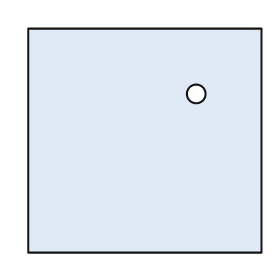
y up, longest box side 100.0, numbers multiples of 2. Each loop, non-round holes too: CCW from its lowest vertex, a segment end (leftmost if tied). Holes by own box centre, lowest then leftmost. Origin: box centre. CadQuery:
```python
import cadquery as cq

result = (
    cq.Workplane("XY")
    .moveTo(-50.0, -48.0)
    .lineTo(50.0, -48.0)
    .lineTo(50.0, 48.0)
    .lineTo(-50.0, 48.0)
    .close()
    .moveTo(22.0, 20.0)
    .circle(4.0)
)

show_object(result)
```